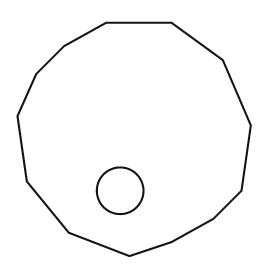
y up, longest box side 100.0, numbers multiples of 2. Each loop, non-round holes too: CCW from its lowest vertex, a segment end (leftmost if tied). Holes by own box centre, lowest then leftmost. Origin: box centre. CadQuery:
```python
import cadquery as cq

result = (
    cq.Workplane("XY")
    .moveTo(-2.0, -50.0)
    .lineTo(16.0, -44.0)
    .lineTo(34.0, -34.0)
    .lineTo(46.0, -22.0)
    .lineTo(50.0, 6.0)
    .lineTo(38.0, 34.0)
    .lineTo(16.0, 50.0)
    .lineTo(-12.0, 50.0)
    .lineTo(-30.0, 40.0)
    .lineTo(-42.0, 28.0)
    .lineTo(-50.0, 10.0)
    .lineTo(-46.0, -18.0)
    .lineTo(-28.0, -40.0)
    .close()
    .moveTo(-6.0, -22.0)
    .circle(10.0)
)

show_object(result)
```